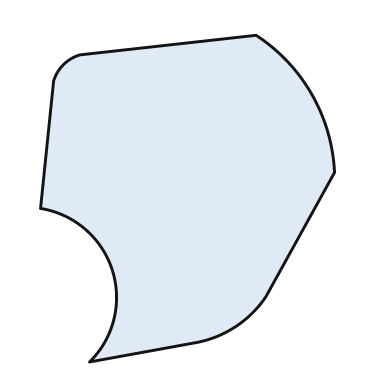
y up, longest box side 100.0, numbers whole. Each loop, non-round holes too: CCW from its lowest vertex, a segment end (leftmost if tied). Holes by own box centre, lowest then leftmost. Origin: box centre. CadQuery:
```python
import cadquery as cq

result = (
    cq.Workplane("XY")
    .moveTo(-30.0, -50.0)
    .lineTo(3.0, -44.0)
    .threePointArc((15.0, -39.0), (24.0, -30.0))
    .lineTo(45.0, 8.0)
    .threePointArc((38.0, 32.0), (21.0, 50.0))
    .lineTo(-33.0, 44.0)
    .threePointArc((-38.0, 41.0), (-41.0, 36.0))
    .lineTo(-45.0, -3.0)
    .threePointArc((-23.0, -22.0), (-30.0, -50.0))
    .close()
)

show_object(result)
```